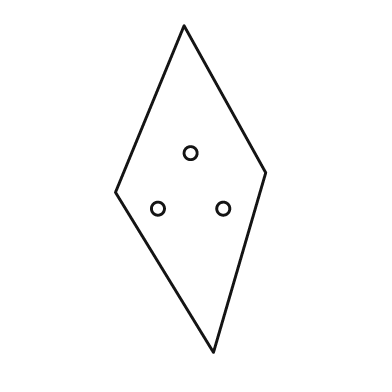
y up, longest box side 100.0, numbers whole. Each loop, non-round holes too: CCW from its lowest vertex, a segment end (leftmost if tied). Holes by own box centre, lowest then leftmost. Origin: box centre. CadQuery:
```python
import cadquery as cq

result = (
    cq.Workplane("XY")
    .moveTo(7.0, -50.0)
    .lineTo(23.0, 5.0)
    .lineTo(-2.0, 50.0)
    .lineTo(-23.0, -1.0)
    .close()
    .moveTo(-10.0, -6.0)
    .circle(2.0)
    .moveTo(10.0, -6.0)
    .circle(2.0)
    .moveTo(0.0, 11.0)
    .circle(2.0)
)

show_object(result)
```